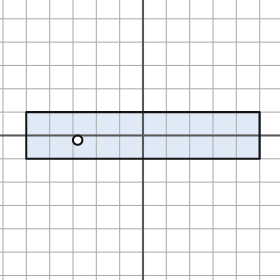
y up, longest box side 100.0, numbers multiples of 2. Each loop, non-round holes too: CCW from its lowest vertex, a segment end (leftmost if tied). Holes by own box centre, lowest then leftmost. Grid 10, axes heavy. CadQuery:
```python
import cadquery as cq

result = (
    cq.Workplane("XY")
    .moveTo(-50.0, -10.0)
    .lineTo(50.0, -10.0)
    .lineTo(50.0, 10.0)
    .lineTo(-50.0, 10.0)
    .close()
    .moveTo(-28.0, -2.0)
    .circle(2.0)
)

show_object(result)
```